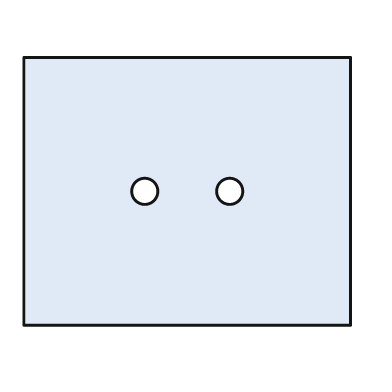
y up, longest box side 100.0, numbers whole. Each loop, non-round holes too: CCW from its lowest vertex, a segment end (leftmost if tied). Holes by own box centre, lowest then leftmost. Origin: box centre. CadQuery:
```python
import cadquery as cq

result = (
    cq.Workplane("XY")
    .moveTo(-50.0, -41.0)
    .lineTo(50.0, -41.0)
    .lineTo(50.0, 41.0)
    .lineTo(-50.0, 41.0)
    .close()
    .moveTo(-13.0, 0.0)
    .circle(4.0)
    .moveTo(13.0, 0.0)
    .circle(4.0)
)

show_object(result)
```